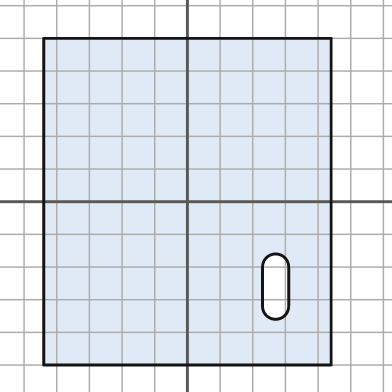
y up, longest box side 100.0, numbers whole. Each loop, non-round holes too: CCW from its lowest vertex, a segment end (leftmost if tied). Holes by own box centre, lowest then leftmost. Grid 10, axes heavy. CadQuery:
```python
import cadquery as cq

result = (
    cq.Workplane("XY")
    .moveTo(-44.0, -50.0)
    .lineTo(44.0, -50.0)
    .lineTo(44.0, 50.0)
    .lineTo(-44.0, 50.0)
    .close()
    .moveTo(23.0, -32.0)
    .threePointArc((27.0, -36.0), (31.0, -32.0))
    .lineTo(31.0, -20.0)
    .threePointArc((27.0, -16.0), (23.0, -20.0))
    .close()
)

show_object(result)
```